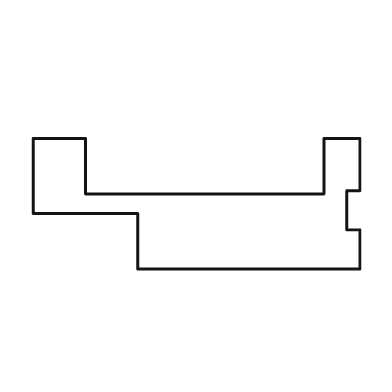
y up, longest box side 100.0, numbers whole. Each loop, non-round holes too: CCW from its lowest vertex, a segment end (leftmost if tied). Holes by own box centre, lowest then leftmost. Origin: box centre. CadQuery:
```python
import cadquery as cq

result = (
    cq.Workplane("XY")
    .moveTo(-18.0, -20.0)
    .lineTo(50.0, -20.0)
    .lineTo(50.0, -8.0)
    .lineTo(46.0, -8.0)
    .lineTo(46.0, 4.0)
    .lineTo(50.0, 4.0)
    .lineTo(50.0, 20.0)
    .lineTo(39.0, 20.0)
    .lineTo(39.0, 3.0)
    .lineTo(-34.0, 3.0)
    .lineTo(-34.0, 20.0)
    .lineTo(-50.0, 20.0)
    .lineTo(-50.0, -3.0)
    .lineTo(-18.0, -3.0)
    .close()
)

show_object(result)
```